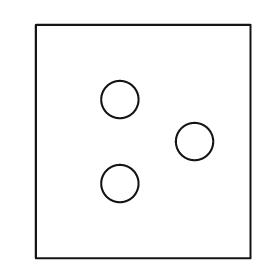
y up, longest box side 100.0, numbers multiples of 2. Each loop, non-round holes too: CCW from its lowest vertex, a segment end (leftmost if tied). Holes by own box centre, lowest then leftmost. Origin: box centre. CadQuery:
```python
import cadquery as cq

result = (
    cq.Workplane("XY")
    .moveTo(-46.0, -50.0)
    .lineTo(46.0, -50.0)
    .lineTo(46.0, 50.0)
    .lineTo(-46.0, 50.0)
    .close()
    .moveTo(-10.0, -18.0)
    .circle(8.0)
    .moveTo(22.0, 0.0)
    .circle(8.0)
    .moveTo(-10.0, 18.0)
    .circle(8.0)
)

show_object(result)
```